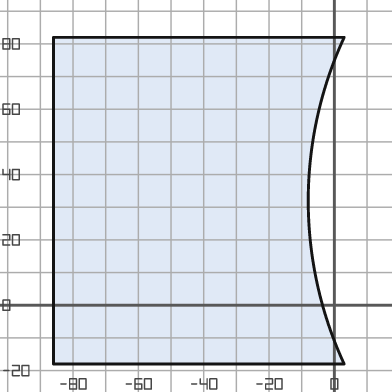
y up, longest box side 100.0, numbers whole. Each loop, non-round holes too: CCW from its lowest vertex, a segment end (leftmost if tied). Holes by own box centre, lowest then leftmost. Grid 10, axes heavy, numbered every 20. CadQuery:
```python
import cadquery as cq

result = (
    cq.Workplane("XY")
    .moveTo(-86.0, -18.0)
    .lineTo(3.0, -18.0)
    .threePointArc((-8.0, 32.0), (3.0, 82.0))
    .lineTo(-86.0, 82.0)
    .close()
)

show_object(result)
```